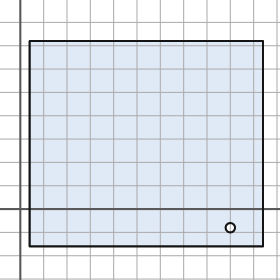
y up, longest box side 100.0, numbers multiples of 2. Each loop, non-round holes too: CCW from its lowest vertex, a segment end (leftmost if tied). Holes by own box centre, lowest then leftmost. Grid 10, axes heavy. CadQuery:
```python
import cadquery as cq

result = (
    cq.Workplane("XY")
    .moveTo(4.0, -16.0)
    .lineTo(104.0, -16.0)
    .lineTo(104.0, 72.0)
    .lineTo(4.0, 72.0)
    .close()
    .moveTo(90.0, -8.0)
    .circle(2.0)
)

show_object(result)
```